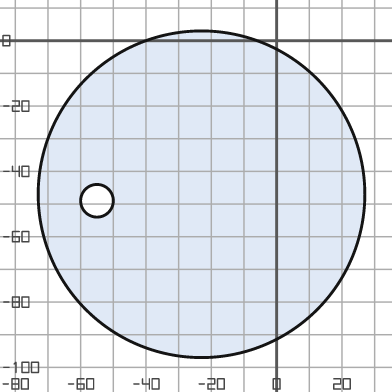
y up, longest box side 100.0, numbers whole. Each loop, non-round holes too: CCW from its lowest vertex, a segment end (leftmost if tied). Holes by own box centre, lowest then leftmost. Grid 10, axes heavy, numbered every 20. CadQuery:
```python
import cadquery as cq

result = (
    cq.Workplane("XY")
    .moveTo(-23.0, -47.0)
    .circle(50.0)
    .moveTo(-55.0, -49.0)
    .circle(5.0)
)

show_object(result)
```